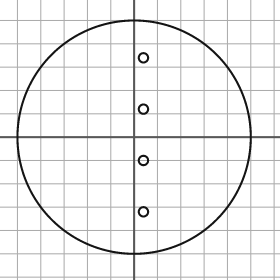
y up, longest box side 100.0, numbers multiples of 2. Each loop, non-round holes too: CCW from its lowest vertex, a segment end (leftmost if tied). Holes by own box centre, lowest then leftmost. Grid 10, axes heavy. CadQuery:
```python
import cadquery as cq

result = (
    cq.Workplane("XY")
    .moveTo(0.0, 0.0)
    .circle(50.0)
    .moveTo(4.0, -32.0)
    .circle(2.0)
    .moveTo(4.0, -10.0)
    .circle(2.0)
    .moveTo(4.0, 12.0)
    .circle(2.0)
    .moveTo(4.0, 34.0)
    .circle(2.0)
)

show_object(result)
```